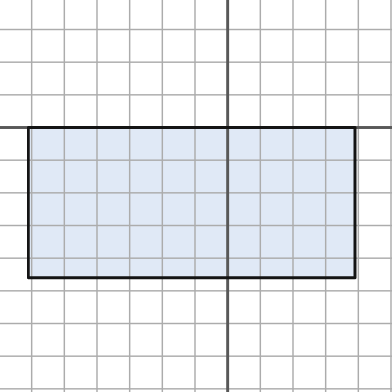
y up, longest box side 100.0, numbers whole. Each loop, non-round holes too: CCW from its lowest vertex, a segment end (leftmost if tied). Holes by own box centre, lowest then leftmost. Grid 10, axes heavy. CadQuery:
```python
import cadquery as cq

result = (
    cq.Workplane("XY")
    .moveTo(-61.0, -46.0)
    .lineTo(39.0, -46.0)
    .lineTo(39.0, 0.0)
    .lineTo(-61.0, 0.0)
    .close()
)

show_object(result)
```